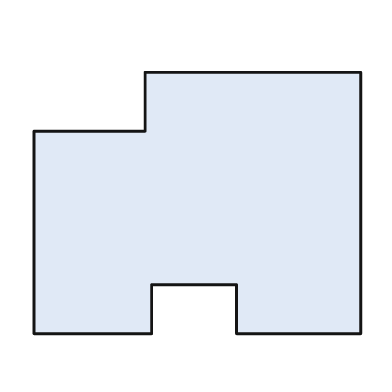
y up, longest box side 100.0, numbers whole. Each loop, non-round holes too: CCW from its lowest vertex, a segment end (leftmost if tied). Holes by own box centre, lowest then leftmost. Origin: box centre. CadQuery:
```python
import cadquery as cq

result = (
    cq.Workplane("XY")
    .moveTo(-50.0, -40.0)
    .lineTo(-14.0, -40.0)
    .lineTo(-14.0, -25.0)
    .lineTo(12.0, -25.0)
    .lineTo(12.0, -40.0)
    .lineTo(50.0, -40.0)
    .lineTo(50.0, 40.0)
    .lineTo(-16.0, 40.0)
    .lineTo(-16.0, 22.0)
    .lineTo(-50.0, 22.0)
    .close()
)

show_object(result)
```